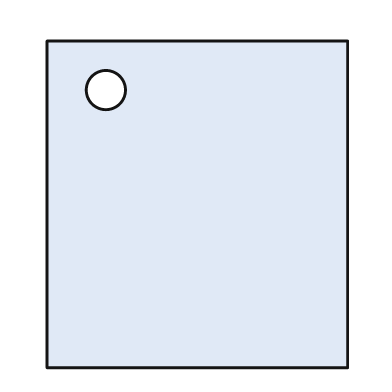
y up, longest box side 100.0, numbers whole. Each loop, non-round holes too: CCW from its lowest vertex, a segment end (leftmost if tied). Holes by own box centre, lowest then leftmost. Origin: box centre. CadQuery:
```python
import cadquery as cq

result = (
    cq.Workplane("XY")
    .moveTo(-46.0, -50.0)
    .lineTo(46.0, -50.0)
    .lineTo(46.0, 50.0)
    .lineTo(-46.0, 50.0)
    .close()
    .moveTo(-28.0, 35.0)
    .circle(6.0)
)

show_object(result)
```